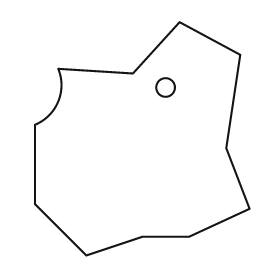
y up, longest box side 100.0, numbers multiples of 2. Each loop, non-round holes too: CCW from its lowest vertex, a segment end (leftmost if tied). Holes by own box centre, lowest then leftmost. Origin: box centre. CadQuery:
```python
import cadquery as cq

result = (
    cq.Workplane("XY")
    .moveTo(-24.0, -50.0)
    .lineTo(0.0, -42.0)
    .lineTo(20.0, -42.0)
    .lineTo(46.0, -30.0)
    .lineTo(36.0, -4.0)
    .lineTo(42.0, 36.0)
    .lineTo(16.0, 50.0)
    .lineTo(-4.0, 28.0)
    .lineTo(-36.0, 30.0)
    .threePointArc((-36.0, 16.0), (-46.0, 6.0))
    .lineTo(-46.0, -28.0)
    .close()
    .moveTo(10.0, 22.0)
    .circle(4.0)
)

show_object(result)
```